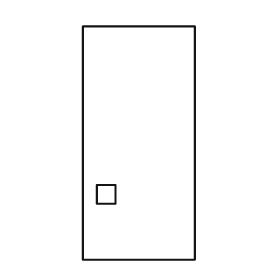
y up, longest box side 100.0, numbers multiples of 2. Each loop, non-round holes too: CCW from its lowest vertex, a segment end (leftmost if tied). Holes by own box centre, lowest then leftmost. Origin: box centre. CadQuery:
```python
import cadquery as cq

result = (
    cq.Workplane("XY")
    .moveTo(-24.0, -50.0)
    .lineTo(24.0, -50.0)
    .lineTo(24.0, 50.0)
    .lineTo(-24.0, 50.0)
    .close()
    .moveTo(-18.0, -26.0)
    .lineTo(-10.0, -26.0)
    .lineTo(-10.0, -18.0)
    .lineTo(-18.0, -18.0)
    .close()
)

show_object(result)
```